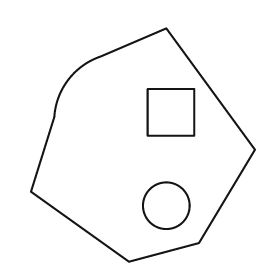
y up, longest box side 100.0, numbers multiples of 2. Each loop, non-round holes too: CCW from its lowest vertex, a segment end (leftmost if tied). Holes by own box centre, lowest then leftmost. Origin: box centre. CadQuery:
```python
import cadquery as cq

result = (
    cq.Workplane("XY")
    .moveTo(-6.0, -50.0)
    .lineTo(24.0, -42.0)
    .lineTo(48.0, -2.0)
    .lineTo(10.0, 50.0)
    .lineTo(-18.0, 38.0)
    .threePointArc((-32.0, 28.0), (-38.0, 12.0))
    .lineTo(-48.0, -20.0)
    .close()
    .moveTo(10.0, -26.0)
    .circle(10.0)
    .moveTo(2.0, 4.0)
    .lineTo(22.0, 4.0)
    .lineTo(22.0, 24.0)
    .lineTo(2.0, 24.0)
    .close()
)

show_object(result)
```